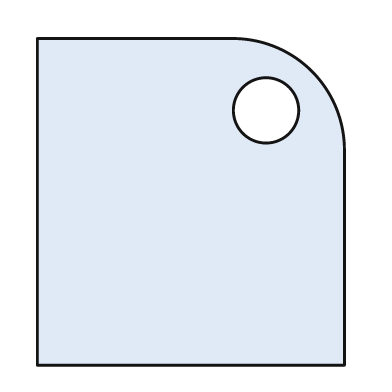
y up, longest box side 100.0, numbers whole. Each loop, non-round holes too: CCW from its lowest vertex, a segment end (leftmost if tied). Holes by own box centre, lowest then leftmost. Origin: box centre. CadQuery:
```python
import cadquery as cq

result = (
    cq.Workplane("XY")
    .moveTo(-47.0, -50.0)
    .lineTo(47.0, -50.0)
    .lineTo(47.0, 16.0)
    .threePointArc((37.0, 40.0), (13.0, 50.0))
    .lineTo(-47.0, 50.0)
    .close()
    .moveTo(23.0, 28.0)
    .circle(10.0)
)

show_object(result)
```